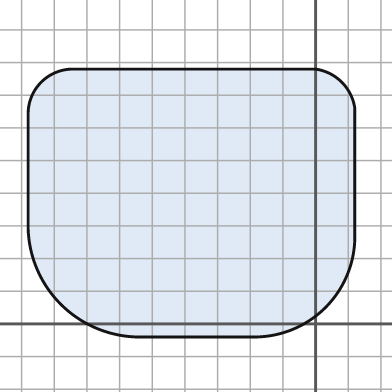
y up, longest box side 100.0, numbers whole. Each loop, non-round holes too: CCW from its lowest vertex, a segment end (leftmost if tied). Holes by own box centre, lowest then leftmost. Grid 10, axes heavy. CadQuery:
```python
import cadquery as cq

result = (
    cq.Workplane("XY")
    .moveTo(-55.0, -4.0)
    .lineTo(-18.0, -4.0)
    .threePointArc((3.0, 5.0), (12.0, 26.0))
    .lineTo(12.0, 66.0)
    .threePointArc((8.0, 74.0), (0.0, 78.0))
    .lineTo(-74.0, 78.0)
    .threePointArc((-84.0, 74.0), (-88.0, 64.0))
    .lineTo(-88.0, 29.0)
    .threePointArc((-78.0, 6.0), (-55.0, -4.0))
    .close()
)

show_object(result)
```